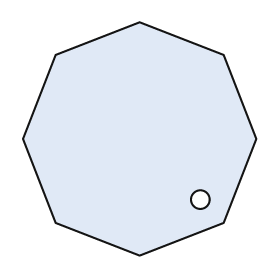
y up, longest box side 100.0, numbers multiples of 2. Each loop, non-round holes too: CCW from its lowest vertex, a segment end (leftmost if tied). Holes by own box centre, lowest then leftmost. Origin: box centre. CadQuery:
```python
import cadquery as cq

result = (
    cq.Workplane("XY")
    .moveTo(0.0, -50.0)
    .lineTo(36.0, -36.0)
    .lineTo(50.0, 0.0)
    .lineTo(36.0, 36.0)
    .lineTo(0.0, 50.0)
    .lineTo(-36.0, 36.0)
    .lineTo(-50.0, 0.0)
    .lineTo(-36.0, -36.0)
    .close()
    .moveTo(26.0, -26.0)
    .circle(4.0)
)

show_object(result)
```